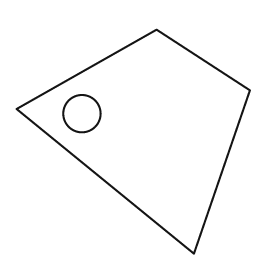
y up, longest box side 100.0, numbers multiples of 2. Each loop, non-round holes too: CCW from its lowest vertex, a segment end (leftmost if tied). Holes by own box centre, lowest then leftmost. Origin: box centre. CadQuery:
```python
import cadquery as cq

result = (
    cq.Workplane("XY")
    .moveTo(26.0, -48.0)
    .lineTo(50.0, 22.0)
    .lineTo(10.0, 48.0)
    .lineTo(-50.0, 14.0)
    .close()
    .moveTo(-22.0, 12.0)
    .circle(8.0)
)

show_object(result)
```